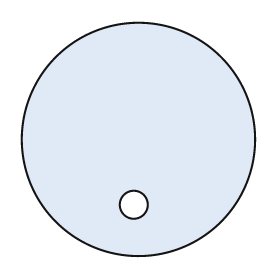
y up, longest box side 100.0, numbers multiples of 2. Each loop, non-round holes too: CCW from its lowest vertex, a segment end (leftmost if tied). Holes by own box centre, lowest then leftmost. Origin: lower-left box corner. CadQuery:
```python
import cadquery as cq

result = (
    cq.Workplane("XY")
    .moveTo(50.0, 50.0)
    .circle(50.0)
    .moveTo(48.0, 22.0)
    .circle(6.0)
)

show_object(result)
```